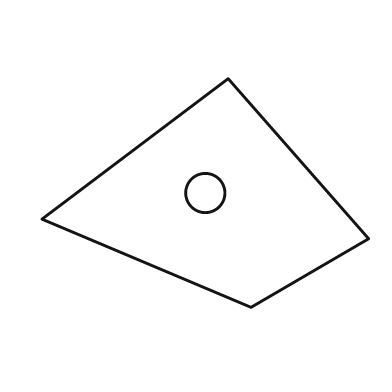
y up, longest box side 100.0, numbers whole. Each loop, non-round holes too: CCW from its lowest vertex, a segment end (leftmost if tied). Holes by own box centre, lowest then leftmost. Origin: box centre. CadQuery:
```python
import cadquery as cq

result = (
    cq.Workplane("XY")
    .moveTo(14.0, -35.0)
    .lineTo(50.0, -14.0)
    .lineTo(7.0, 35.0)
    .lineTo(-50.0, -8.0)
    .close()
    .moveTo(0.0, 0.0)
    .circle(6.0)
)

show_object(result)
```